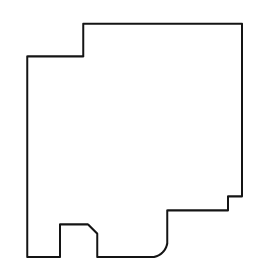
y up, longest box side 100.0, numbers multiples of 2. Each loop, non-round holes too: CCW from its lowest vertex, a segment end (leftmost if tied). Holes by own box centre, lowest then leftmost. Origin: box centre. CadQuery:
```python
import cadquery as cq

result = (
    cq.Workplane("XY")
    .moveTo(-46.0, -50.0)
    .lineTo(-32.0, -50.0)
    .lineTo(-32.0, -36.0)
    .lineTo(-20.0, -36.0)
    .lineTo(-16.0, -40.0)
    .lineTo(-16.0, -50.0)
    .lineTo(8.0, -50.0)
    .threePointArc((12.0, -48.0), (14.0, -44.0))
    .lineTo(14.0, -30.0)
    .lineTo(40.0, -30.0)
    .lineTo(40.0, -24.0)
    .lineTo(46.0, -24.0)
    .lineTo(46.0, 50.0)
    .lineTo(-22.0, 50.0)
    .lineTo(-22.0, 36.0)
    .lineTo(-46.0, 36.0)
    .close()
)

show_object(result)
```